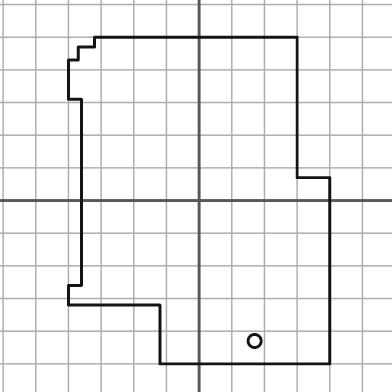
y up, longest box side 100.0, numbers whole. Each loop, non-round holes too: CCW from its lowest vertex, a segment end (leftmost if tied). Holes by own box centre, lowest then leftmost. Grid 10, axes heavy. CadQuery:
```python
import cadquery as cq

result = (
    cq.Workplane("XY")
    .moveTo(-12.0, -50.0)
    .lineTo(40.0, -50.0)
    .lineTo(40.0, 7.0)
    .lineTo(30.0, 7.0)
    .lineTo(30.0, 50.0)
    .lineTo(-32.0, 50.0)
    .lineTo(-32.0, 47.0)
    .lineTo(-37.0, 47.0)
    .lineTo(-37.0, 43.0)
    .lineTo(-40.0, 43.0)
    .lineTo(-40.0, 31.0)
    .lineTo(-36.0, 31.0)
    .lineTo(-36.0, -26.0)
    .lineTo(-40.0, -26.0)
    .lineTo(-40.0, -32.0)
    .lineTo(-12.0, -32.0)
    .close()
    .moveTo(17.0, -43.0)
    .circle(2.0)
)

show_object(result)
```